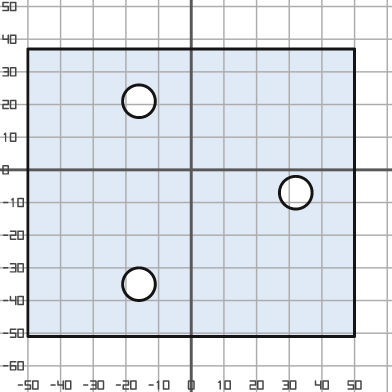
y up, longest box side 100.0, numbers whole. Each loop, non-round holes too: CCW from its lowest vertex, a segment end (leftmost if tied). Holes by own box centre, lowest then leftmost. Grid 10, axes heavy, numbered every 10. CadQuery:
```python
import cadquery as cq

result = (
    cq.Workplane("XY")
    .moveTo(-50.0, -51.0)
    .lineTo(50.0, -51.0)
    .lineTo(50.0, 37.0)
    .lineTo(-50.0, 37.0)
    .close()
    .moveTo(-16.0, -35.0)
    .circle(5.0)
    .moveTo(32.0, -7.0)
    .circle(5.0)
    .moveTo(-16.0, 21.0)
    .circle(5.0)
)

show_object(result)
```